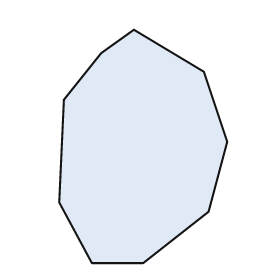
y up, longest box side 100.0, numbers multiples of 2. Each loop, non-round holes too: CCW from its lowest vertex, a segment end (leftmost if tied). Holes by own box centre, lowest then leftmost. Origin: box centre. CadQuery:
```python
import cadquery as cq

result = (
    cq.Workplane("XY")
    .moveTo(-22.0, -50.0)
    .lineTo(0.0, -50.0)
    .lineTo(28.0, -28.0)
    .lineTo(36.0, 2.0)
    .lineTo(26.0, 32.0)
    .lineTo(-4.0, 50.0)
    .lineTo(-18.0, 40.0)
    .lineTo(-34.0, 20.0)
    .lineTo(-36.0, -24.0)
    .close()
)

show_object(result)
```